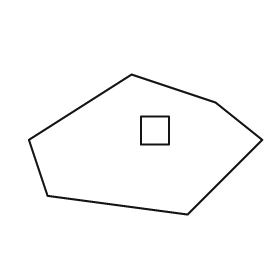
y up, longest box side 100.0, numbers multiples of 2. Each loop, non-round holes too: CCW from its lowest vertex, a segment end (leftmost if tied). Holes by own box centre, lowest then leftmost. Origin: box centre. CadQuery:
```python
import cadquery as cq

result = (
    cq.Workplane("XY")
    .moveTo(18.0, -30.0)
    .lineTo(50.0, 2.0)
    .lineTo(30.0, 18.0)
    .lineTo(-6.0, 30.0)
    .lineTo(-50.0, 2.0)
    .lineTo(-42.0, -22.0)
    .close()
    .moveTo(-2.0, 0.0)
    .lineTo(10.0, 0.0)
    .lineTo(10.0, 12.0)
    .lineTo(-2.0, 12.0)
    .close()
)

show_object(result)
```